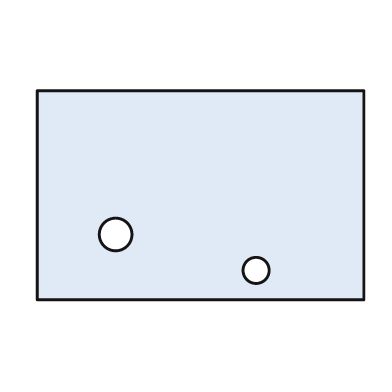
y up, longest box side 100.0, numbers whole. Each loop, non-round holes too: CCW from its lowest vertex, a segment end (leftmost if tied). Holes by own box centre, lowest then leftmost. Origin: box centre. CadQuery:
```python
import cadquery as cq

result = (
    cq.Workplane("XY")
    .moveTo(-50.0, -32.0)
    .lineTo(50.0, -32.0)
    .lineTo(50.0, 32.0)
    .lineTo(-50.0, 32.0)
    .close()
    .moveTo(17.0, -23.0)
    .circle(4.0)
    .moveTo(-26.0, -12.0)
    .circle(5.0)
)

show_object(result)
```